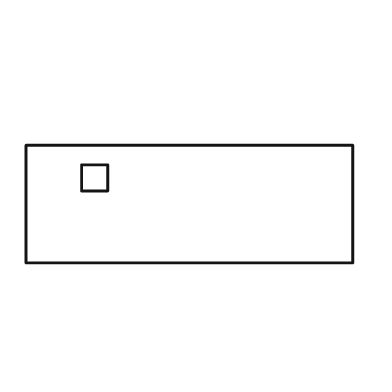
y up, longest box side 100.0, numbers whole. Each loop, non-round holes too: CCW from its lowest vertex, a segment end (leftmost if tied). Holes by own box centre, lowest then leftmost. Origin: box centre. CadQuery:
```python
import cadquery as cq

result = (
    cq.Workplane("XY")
    .moveTo(-50.0, -18.0)
    .lineTo(50.0, -18.0)
    .lineTo(50.0, 18.0)
    .lineTo(-50.0, 18.0)
    .close()
    .moveTo(-33.0, 4.0)
    .lineTo(-25.0, 4.0)
    .lineTo(-25.0, 12.0)
    .lineTo(-33.0, 12.0)
    .close()
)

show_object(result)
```